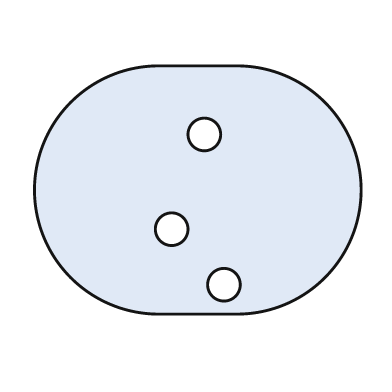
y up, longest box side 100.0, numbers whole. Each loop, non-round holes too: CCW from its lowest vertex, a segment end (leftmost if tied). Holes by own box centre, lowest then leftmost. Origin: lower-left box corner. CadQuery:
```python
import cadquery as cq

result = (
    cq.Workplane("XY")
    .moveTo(38.0, 0.0)
    .lineTo(62.0, 0.0)
    .threePointArc((100.0, 38.0), (62.0, 76.0))
    .lineTo(38.0, 76.0)
    .threePointArc((0.0, 38.0), (38.0, 0.0))
    .close()
    .moveTo(58.0, 9.0)
    .circle(5.0)
    .moveTo(42.0, 26.0)
    .circle(5.0)
    .moveTo(52.0, 55.0)
    .circle(5.0)
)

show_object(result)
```